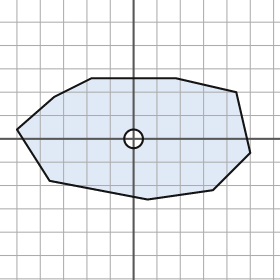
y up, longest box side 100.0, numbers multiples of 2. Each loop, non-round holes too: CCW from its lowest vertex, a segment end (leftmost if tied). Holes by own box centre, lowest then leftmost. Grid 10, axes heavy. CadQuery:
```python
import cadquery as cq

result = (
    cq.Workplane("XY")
    .moveTo(6.0, -26.0)
    .lineTo(34.0, -22.0)
    .lineTo(50.0, -6.0)
    .lineTo(44.0, 20.0)
    .lineTo(18.0, 26.0)
    .lineTo(-18.0, 26.0)
    .lineTo(-34.0, 18.0)
    .lineTo(-50.0, 4.0)
    .lineTo(-36.0, -18.0)
    .close()
    .moveTo(0.0, 0.0)
    .circle(4.0)
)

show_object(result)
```